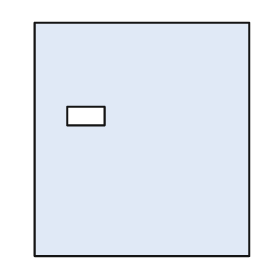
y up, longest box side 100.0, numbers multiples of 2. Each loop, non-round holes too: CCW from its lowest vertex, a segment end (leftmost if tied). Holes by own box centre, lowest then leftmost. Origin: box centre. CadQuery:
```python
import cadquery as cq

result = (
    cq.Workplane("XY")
    .moveTo(-46.0, -50.0)
    .lineTo(46.0, -50.0)
    .lineTo(46.0, 50.0)
    .lineTo(-46.0, 50.0)
    .close()
    .moveTo(-32.0, 6.0)
    .lineTo(-16.0, 6.0)
    .lineTo(-16.0, 14.0)
    .lineTo(-32.0, 14.0)
    .close()
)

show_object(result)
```